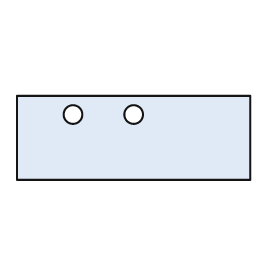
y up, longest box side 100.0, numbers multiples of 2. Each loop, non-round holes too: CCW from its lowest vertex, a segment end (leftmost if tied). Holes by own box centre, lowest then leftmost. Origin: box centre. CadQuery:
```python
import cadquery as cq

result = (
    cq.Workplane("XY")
    .moveTo(-50.0, -18.0)
    .lineTo(50.0, -18.0)
    .lineTo(50.0, 18.0)
    .lineTo(-50.0, 18.0)
    .close()
    .moveTo(-26.0, 10.0)
    .circle(4.0)
    .moveTo(0.0, 10.0)
    .circle(4.0)
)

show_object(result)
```